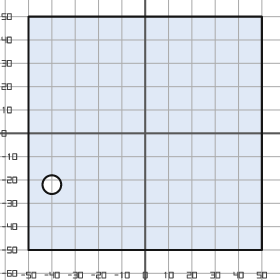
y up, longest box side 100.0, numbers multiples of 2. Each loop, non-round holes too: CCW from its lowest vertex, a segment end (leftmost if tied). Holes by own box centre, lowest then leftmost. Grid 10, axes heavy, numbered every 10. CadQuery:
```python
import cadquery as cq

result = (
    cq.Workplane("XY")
    .moveTo(-50.0, -50.0)
    .lineTo(50.0, -50.0)
    .lineTo(50.0, 50.0)
    .lineTo(-50.0, 50.0)
    .close()
    .moveTo(-40.0, -22.0)
    .circle(4.0)
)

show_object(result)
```